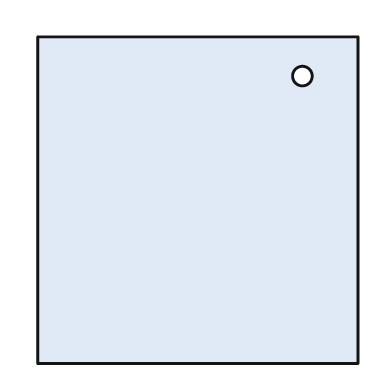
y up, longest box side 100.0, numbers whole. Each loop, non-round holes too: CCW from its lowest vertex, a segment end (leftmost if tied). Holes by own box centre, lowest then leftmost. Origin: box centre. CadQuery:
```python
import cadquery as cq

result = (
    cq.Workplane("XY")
    .moveTo(-49.0, -50.0)
    .lineTo(49.0, -50.0)
    .lineTo(49.0, 50.0)
    .lineTo(-49.0, 50.0)
    .close()
    .moveTo(32.0, 38.0)
    .circle(3.0)
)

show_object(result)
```